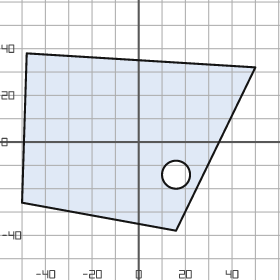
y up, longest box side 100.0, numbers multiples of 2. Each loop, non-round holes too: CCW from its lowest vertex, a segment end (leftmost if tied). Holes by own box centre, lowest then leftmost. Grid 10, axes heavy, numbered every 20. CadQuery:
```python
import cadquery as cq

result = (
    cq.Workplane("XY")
    .moveTo(16.0, -38.0)
    .lineTo(50.0, 32.0)
    .lineTo(-48.0, 38.0)
    .lineTo(-50.0, -26.0)
    .close()
    .moveTo(16.0, -14.0)
    .circle(6.0)
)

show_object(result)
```